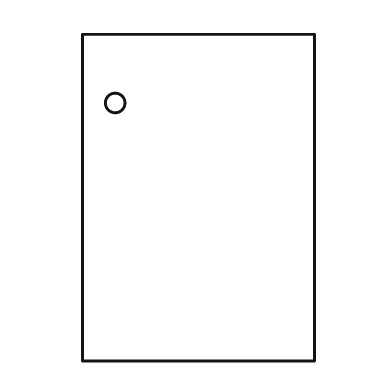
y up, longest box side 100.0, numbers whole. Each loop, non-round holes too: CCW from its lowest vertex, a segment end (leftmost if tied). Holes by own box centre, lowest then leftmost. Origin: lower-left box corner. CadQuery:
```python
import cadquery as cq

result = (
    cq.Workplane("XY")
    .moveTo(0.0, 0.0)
    .lineTo(71.0, 0.0)
    .lineTo(71.0, 100.0)
    .lineTo(0.0, 100.0)
    .close()
    .moveTo(10.0, 79.0)
    .circle(3.0)
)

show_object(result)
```